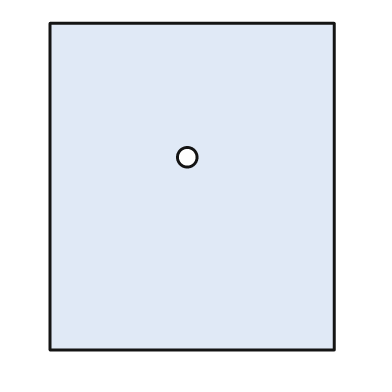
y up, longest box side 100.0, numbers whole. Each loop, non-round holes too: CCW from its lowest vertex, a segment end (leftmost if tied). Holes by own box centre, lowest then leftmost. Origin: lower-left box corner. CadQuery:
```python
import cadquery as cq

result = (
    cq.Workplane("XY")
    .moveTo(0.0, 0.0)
    .lineTo(87.0, 0.0)
    .lineTo(87.0, 100.0)
    .lineTo(0.0, 100.0)
    .close()
    .moveTo(42.0, 59.0)
    .circle(3.0)
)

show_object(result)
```